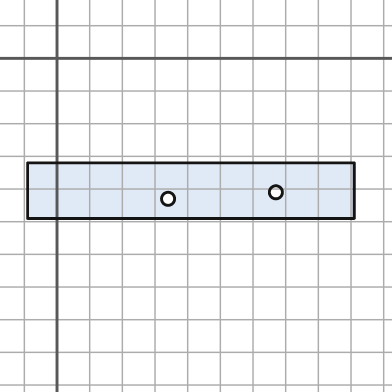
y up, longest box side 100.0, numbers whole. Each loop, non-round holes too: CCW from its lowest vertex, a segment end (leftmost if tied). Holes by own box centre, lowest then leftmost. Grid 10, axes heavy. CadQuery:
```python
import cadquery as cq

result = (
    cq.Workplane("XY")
    .moveTo(-9.0, -49.0)
    .lineTo(91.0, -49.0)
    .lineTo(91.0, -32.0)
    .lineTo(-9.0, -32.0)
    .close()
    .moveTo(34.0, -43.0)
    .circle(2.0)
    .moveTo(67.0, -41.0)
    .circle(2.0)
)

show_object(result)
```